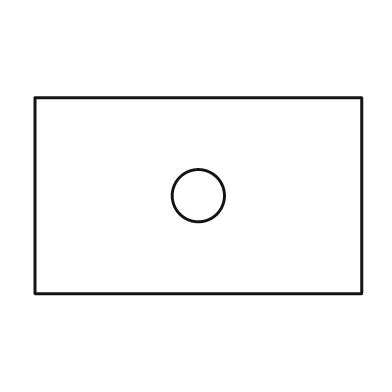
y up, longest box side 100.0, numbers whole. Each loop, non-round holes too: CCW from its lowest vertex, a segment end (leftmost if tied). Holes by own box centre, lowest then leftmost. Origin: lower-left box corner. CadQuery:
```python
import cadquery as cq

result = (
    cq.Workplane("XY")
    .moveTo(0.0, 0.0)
    .lineTo(100.0, 0.0)
    .lineTo(100.0, 60.0)
    .lineTo(0.0, 60.0)
    .close()
    .moveTo(50.0, 30.0)
    .circle(8.0)
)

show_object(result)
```